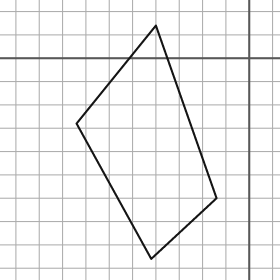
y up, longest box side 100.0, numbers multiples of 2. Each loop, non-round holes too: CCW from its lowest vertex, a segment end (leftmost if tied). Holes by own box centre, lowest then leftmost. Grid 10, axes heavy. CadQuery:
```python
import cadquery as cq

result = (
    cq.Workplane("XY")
    .moveTo(-42.0, -86.0)
    .lineTo(-14.0, -60.0)
    .lineTo(-40.0, 14.0)
    .lineTo(-74.0, -28.0)
    .close()
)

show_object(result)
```